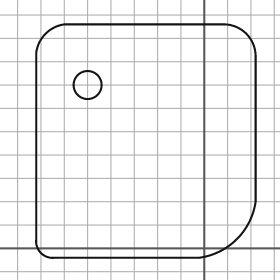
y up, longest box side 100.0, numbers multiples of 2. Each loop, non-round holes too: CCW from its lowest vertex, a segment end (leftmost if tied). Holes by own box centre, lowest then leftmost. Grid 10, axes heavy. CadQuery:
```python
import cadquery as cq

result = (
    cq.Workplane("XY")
    .moveTo(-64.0, -4.0)
    .lineTo(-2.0, -4.0)
    .threePointArc((14.0, 4.0), (22.0, 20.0))
    .lineTo(22.0, 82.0)
    .threePointArc((18.0, 92.0), (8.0, 96.0))
    .lineTo(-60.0, 96.0)
    .threePointArc((-68.0, 92.0), (-72.0, 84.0))
    .lineTo(-72.0, 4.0)
    .threePointArc((-70.0, -2.0), (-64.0, -4.0))
    .close()
    .moveTo(-50.0, 70.0)
    .circle(6.0)
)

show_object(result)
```